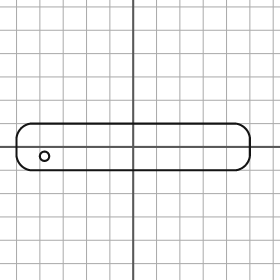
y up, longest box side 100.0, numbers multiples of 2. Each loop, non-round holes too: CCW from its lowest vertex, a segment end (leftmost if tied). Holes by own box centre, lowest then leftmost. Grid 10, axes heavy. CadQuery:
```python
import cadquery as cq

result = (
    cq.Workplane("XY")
    .moveTo(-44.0, -10.0)
    .lineTo(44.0, -10.0)
    .threePointArc((48.0, -8.0), (50.0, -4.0))
    .lineTo(50.0, 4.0)
    .threePointArc((48.0, 8.0), (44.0, 10.0))
    .lineTo(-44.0, 10.0)
    .threePointArc((-48.0, 8.0), (-50.0, 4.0))
    .lineTo(-50.0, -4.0)
    .threePointArc((-48.0, -8.0), (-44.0, -10.0))
    .close()
    .moveTo(-38.0, -4.0)
    .circle(2.0)
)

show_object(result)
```